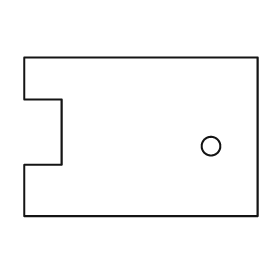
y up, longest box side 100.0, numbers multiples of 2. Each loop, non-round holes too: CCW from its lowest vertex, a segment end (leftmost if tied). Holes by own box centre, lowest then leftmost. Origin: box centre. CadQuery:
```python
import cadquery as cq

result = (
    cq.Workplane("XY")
    .moveTo(-50.0, -34.0)
    .lineTo(50.0, -34.0)
    .lineTo(50.0, 34.0)
    .lineTo(-50.0, 34.0)
    .lineTo(-50.0, 16.0)
    .lineTo(-34.0, 16.0)
    .lineTo(-34.0, -12.0)
    .lineTo(-50.0, -12.0)
    .close()
    .moveTo(30.0, -4.0)
    .circle(4.0)
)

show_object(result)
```